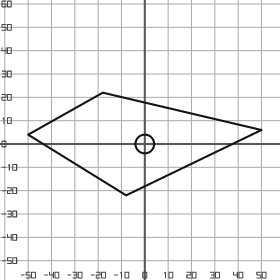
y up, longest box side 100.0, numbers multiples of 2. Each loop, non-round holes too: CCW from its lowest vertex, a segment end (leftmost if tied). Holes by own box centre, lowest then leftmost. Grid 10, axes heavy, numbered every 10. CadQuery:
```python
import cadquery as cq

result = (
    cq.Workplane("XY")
    .moveTo(-8.0, -22.0)
    .lineTo(50.0, 6.0)
    .lineTo(-18.0, 22.0)
    .lineTo(-50.0, 4.0)
    .close()
    .moveTo(0.0, 0.0)
    .circle(4.0)
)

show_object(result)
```